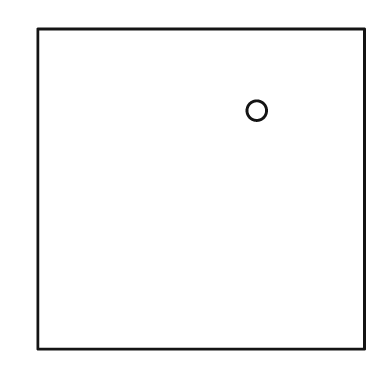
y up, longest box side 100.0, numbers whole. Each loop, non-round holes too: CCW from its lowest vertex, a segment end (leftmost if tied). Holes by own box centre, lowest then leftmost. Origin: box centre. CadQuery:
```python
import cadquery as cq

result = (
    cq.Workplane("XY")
    .moveTo(-50.0, -49.0)
    .lineTo(50.0, -49.0)
    .lineTo(50.0, 49.0)
    .lineTo(-50.0, 49.0)
    .close()
    .moveTo(17.0, 24.0)
    .circle(3.0)
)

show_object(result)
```